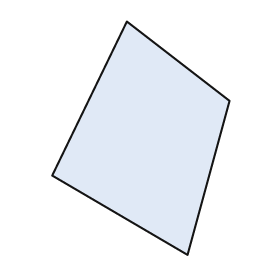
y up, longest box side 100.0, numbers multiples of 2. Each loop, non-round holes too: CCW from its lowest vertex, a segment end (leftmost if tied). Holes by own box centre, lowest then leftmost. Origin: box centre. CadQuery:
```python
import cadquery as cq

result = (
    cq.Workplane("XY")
    .moveTo(20.0, -50.0)
    .lineTo(38.0, 16.0)
    .lineTo(-6.0, 50.0)
    .lineTo(-38.0, -16.0)
    .close()
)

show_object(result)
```